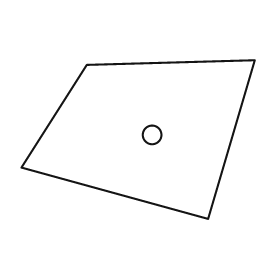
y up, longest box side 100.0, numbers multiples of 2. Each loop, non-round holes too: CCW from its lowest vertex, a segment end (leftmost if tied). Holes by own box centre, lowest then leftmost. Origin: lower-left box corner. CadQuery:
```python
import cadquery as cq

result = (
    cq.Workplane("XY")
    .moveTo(80.0, 0.0)
    .lineTo(100.0, 68.0)
    .lineTo(28.0, 66.0)
    .lineTo(0.0, 22.0)
    .close()
    .moveTo(56.0, 36.0)
    .circle(4.0)
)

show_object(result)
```